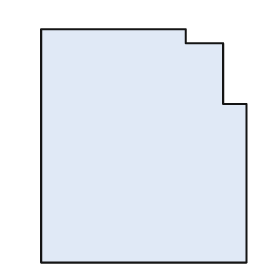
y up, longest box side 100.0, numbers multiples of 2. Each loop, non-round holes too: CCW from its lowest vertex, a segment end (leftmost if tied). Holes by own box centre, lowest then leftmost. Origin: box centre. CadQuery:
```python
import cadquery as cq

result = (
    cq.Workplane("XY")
    .moveTo(-44.0, -50.0)
    .lineTo(44.0, -50.0)
    .lineTo(44.0, 18.0)
    .lineTo(34.0, 18.0)
    .lineTo(34.0, 44.0)
    .lineTo(18.0, 44.0)
    .lineTo(18.0, 50.0)
    .lineTo(-44.0, 50.0)
    .close()
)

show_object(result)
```